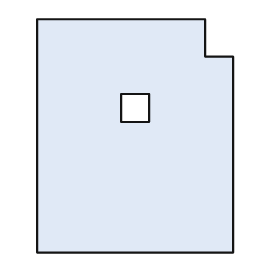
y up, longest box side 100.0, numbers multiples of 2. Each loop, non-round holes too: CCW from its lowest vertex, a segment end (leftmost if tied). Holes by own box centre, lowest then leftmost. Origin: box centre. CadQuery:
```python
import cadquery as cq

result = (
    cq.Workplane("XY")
    .moveTo(-42.0, -50.0)
    .lineTo(42.0, -50.0)
    .lineTo(42.0, 34.0)
    .lineTo(30.0, 34.0)
    .lineTo(30.0, 50.0)
    .lineTo(-42.0, 50.0)
    .close()
    .moveTo(-6.0, 6.0)
    .lineTo(6.0, 6.0)
    .lineTo(6.0, 18.0)
    .lineTo(-6.0, 18.0)
    .close()
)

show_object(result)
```